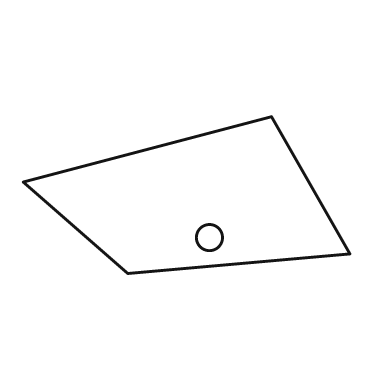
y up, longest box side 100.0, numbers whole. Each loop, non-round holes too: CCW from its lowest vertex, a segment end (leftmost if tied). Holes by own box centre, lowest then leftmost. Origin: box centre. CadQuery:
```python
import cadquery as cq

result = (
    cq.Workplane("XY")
    .moveTo(-18.0, -24.0)
    .lineTo(50.0, -18.0)
    .lineTo(26.0, 24.0)
    .lineTo(-50.0, 4.0)
    .close()
    .moveTo(7.0, -13.0)
    .circle(4.0)
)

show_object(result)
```